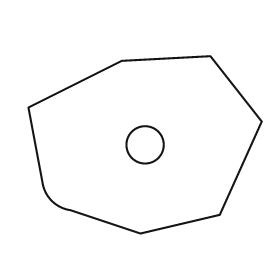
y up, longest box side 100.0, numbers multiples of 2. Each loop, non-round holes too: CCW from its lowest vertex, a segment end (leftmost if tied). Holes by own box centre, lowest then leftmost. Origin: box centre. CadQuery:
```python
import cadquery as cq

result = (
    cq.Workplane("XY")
    .moveTo(-2.0, -38.0)
    .lineTo(32.0, -30.0)
    .lineTo(50.0, 10.0)
    .lineTo(28.0, 38.0)
    .lineTo(-10.0, 36.0)
    .lineTo(-50.0, 16.0)
    .lineTo(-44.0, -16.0)
    .threePointArc((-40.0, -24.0), (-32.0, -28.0))
    .close()
    .moveTo(0.0, 0.0)
    .circle(8.0)
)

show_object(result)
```